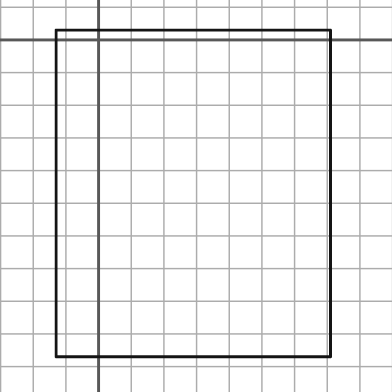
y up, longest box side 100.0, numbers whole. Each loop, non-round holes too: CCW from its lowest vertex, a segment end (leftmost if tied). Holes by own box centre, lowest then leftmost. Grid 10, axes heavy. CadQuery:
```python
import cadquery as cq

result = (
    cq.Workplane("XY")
    .moveTo(-13.0, -97.0)
    .lineTo(71.0, -97.0)
    .lineTo(71.0, 3.0)
    .lineTo(-13.0, 3.0)
    .close()
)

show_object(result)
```